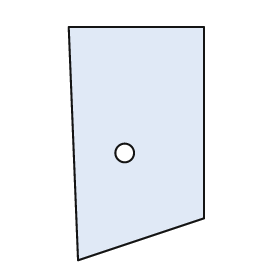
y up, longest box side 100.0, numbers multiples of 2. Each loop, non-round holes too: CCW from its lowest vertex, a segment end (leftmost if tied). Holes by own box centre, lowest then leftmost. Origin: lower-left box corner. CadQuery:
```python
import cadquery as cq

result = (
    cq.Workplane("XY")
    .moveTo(4.0, 0.0)
    .lineTo(58.0, 18.0)
    .lineTo(58.0, 100.0)
    .lineTo(0.0, 100.0)
    .close()
    .moveTo(24.0, 46.0)
    .circle(4.0)
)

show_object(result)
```